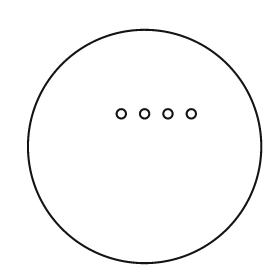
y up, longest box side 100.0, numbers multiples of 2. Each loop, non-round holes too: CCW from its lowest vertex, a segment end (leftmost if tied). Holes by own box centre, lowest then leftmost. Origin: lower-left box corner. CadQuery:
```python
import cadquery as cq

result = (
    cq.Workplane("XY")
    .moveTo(50.0, 50.0)
    .circle(50.0)
    .moveTo(40.0, 64.0)
    .circle(2.0)
    .moveTo(50.0, 64.0)
    .circle(2.0)
    .moveTo(60.0, 64.0)
    .circle(2.0)
    .moveTo(70.0, 64.0)
    .circle(2.0)
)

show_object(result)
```